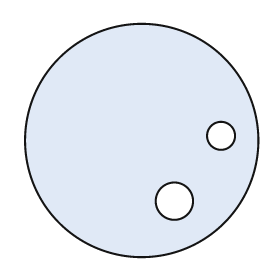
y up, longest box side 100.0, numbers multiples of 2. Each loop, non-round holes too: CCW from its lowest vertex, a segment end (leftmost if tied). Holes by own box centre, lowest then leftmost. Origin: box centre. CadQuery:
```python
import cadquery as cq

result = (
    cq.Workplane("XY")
    .moveTo(0.0, 0.0)
    .circle(50.0)
    .moveTo(14.0, -26.0)
    .circle(8.0)
    .moveTo(34.0, 2.0)
    .circle(6.0)
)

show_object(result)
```